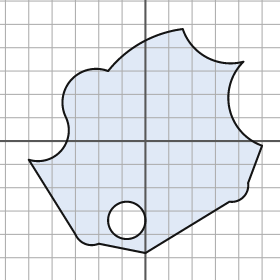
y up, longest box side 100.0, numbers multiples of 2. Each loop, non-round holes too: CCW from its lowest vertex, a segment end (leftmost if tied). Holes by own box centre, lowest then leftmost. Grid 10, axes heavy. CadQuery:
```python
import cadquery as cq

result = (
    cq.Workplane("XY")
    .moveTo(0.0, -48.0)
    .lineTo(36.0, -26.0)
    .threePointArc((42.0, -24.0), (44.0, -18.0))
    .lineTo(50.0, -2.0)
    .threePointArc((36.0, 14.0), (42.0, 34.0))
    .threePointArc((26.0, 36.0), (16.0, 48.0))
    .threePointArc((-2.0, 42.0), (-16.0, 30.0))
    .threePointArc((-32.0, 26.0), (-34.0, 10.0))
    .threePointArc((-36.0, -4.0), (-50.0, -8.0))
    .lineTo(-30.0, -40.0)
    .threePointArc((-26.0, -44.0), (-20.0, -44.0))
    .close()
    .moveTo(-8.0, -34.0)
    .circle(8.0)
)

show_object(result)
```